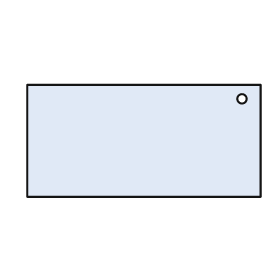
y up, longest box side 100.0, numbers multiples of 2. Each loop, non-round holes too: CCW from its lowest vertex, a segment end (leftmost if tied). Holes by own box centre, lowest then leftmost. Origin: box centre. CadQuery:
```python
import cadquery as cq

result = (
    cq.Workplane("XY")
    .moveTo(-50.0, -24.0)
    .lineTo(50.0, -24.0)
    .lineTo(50.0, 24.0)
    .lineTo(-50.0, 24.0)
    .close()
    .moveTo(42.0, 18.0)
    .circle(2.0)
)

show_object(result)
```